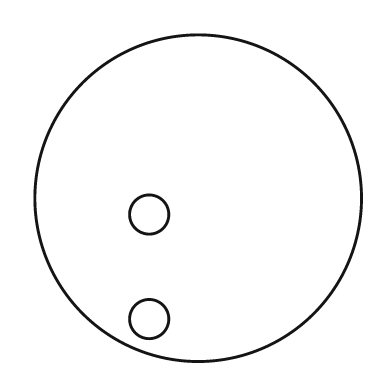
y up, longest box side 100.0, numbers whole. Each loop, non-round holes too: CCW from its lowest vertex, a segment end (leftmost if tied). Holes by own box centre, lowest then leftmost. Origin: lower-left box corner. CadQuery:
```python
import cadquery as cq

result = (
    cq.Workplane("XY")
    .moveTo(50.0, 50.0)
    .circle(50.0)
    .moveTo(35.0, 13.0)
    .circle(6.0)
    .moveTo(35.0, 45.0)
    .circle(6.0)
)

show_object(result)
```